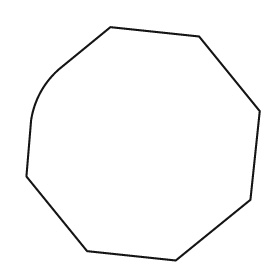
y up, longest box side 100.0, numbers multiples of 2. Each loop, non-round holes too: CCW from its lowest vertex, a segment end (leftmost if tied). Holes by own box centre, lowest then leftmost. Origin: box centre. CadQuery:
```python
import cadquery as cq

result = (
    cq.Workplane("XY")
    .moveTo(14.0, -50.0)
    .lineTo(46.0, -24.0)
    .lineTo(50.0, 14.0)
    .lineTo(24.0, 46.0)
    .lineTo(-14.0, 50.0)
    .lineTo(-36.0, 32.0)
    .threePointArc((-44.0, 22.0), (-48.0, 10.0))
    .lineTo(-50.0, -14.0)
    .lineTo(-24.0, -46.0)
    .close()
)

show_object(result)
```